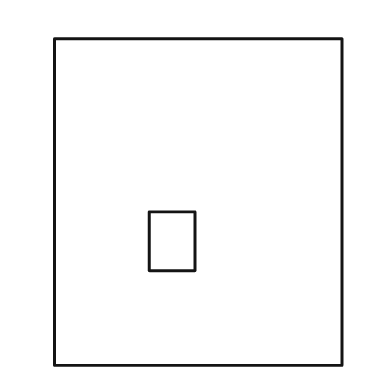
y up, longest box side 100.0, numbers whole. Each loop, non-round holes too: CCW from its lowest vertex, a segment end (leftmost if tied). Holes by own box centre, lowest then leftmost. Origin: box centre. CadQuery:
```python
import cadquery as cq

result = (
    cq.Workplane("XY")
    .moveTo(-44.0, -50.0)
    .lineTo(44.0, -50.0)
    .lineTo(44.0, 50.0)
    .lineTo(-44.0, 50.0)
    .close()
    .moveTo(-15.0, -21.0)
    .lineTo(-1.0, -21.0)
    .lineTo(-1.0, -3.0)
    .lineTo(-15.0, -3.0)
    .close()
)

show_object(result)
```